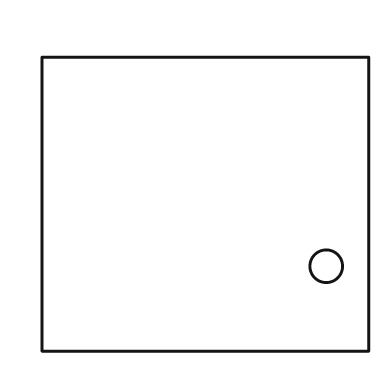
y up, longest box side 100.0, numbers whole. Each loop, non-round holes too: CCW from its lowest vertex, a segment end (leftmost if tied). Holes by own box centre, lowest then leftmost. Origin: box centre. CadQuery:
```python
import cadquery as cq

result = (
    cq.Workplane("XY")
    .moveTo(-50.0, -45.0)
    .lineTo(50.0, -45.0)
    .lineTo(50.0, 45.0)
    .lineTo(-50.0, 45.0)
    .close()
    .moveTo(37.0, -19.0)
    .circle(5.0)
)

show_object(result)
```